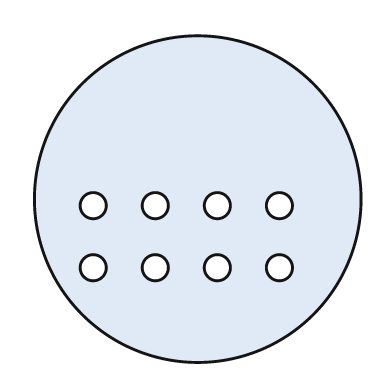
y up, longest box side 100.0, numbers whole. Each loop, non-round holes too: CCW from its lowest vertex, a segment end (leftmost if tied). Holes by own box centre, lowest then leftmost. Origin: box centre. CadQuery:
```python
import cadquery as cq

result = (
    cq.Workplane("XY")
    .moveTo(0.0, 0.0)
    .circle(50.0)
    .moveTo(-32.0, -21.0)
    .circle(4.0)
    .moveTo(-13.0, -21.0)
    .circle(4.0)
    .moveTo(6.0, -21.0)
    .circle(4.0)
    .moveTo(25.0, -21.0)
    .circle(4.0)
    .moveTo(-32.0, -2.0)
    .circle(4.0)
    .moveTo(-13.0, -2.0)
    .circle(4.0)
    .moveTo(6.0, -2.0)
    .circle(4.0)
    .moveTo(25.0, -2.0)
    .circle(4.0)
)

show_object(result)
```